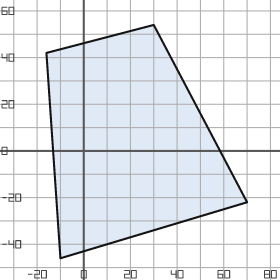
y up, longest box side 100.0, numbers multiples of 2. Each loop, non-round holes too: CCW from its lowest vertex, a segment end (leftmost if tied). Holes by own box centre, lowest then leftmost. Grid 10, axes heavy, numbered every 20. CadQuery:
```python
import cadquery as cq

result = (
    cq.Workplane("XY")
    .moveTo(-10.0, -46.0)
    .lineTo(70.0, -22.0)
    .lineTo(30.0, 54.0)
    .lineTo(-16.0, 42.0)
    .close()
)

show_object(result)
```